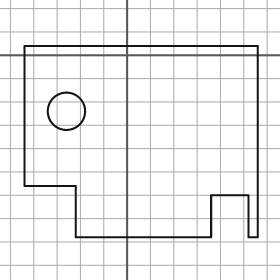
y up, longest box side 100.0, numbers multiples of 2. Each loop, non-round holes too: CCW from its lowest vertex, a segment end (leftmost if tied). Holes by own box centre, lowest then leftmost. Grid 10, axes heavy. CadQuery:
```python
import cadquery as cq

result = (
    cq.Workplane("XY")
    .moveTo(-22.0, -78.0)
    .lineTo(36.0, -78.0)
    .lineTo(36.0, -60.0)
    .lineTo(52.0, -60.0)
    .lineTo(52.0, -78.0)
    .lineTo(56.0, -78.0)
    .lineTo(56.0, 4.0)
    .lineTo(-44.0, 4.0)
    .lineTo(-44.0, -56.0)
    .lineTo(-22.0, -56.0)
    .close()
    .moveTo(-26.0, -24.0)
    .circle(8.0)
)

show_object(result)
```